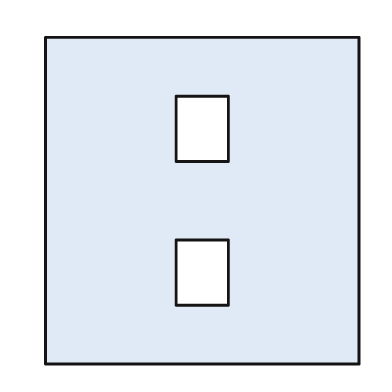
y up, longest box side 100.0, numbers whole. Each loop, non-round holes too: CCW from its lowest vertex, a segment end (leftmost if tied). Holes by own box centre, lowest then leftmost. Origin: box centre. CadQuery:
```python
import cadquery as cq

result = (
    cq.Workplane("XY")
    .moveTo(-48.0, -50.0)
    .lineTo(48.0, -50.0)
    .lineTo(48.0, 50.0)
    .lineTo(-48.0, 50.0)
    .close()
    .moveTo(-8.0, -32.0)
    .lineTo(8.0, -32.0)
    .lineTo(8.0, -12.0)
    .lineTo(-8.0, -12.0)
    .close()
    .moveTo(-8.0, 12.0)
    .lineTo(8.0, 12.0)
    .lineTo(8.0, 32.0)
    .lineTo(-8.0, 32.0)
    .close()
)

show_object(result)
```